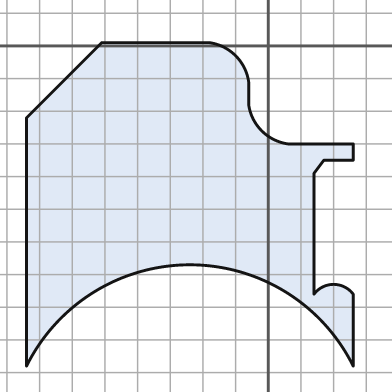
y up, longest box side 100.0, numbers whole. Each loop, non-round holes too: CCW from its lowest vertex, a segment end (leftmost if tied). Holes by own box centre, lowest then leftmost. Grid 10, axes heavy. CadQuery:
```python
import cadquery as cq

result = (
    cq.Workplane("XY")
    .moveTo(-74.0, -98.0)
    .threePointArc((-24.0, -67.0), (26.0, -98.0))
    .lineTo(26.0, -76.0)
    .threePointArc((20.0, -73.0), (14.0, -76.0))
    .lineTo(14.0, -39.0)
    .lineTo(17.0, -35.0)
    .lineTo(26.0, -35.0)
    .lineTo(26.0, -30.0)
    .lineTo(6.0, -30.0)
    .threePointArc((-2.0, -26.0), (-6.0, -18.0))
    .lineTo(-6.0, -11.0)
    .threePointArc((-10.0, -3.0), (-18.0, 1.0))
    .lineTo(-51.0, 1.0)
    .lineTo(-74.0, -22.0)
    .close()
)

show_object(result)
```